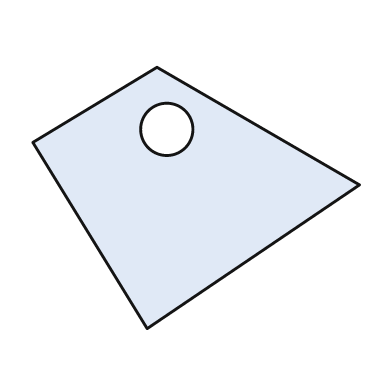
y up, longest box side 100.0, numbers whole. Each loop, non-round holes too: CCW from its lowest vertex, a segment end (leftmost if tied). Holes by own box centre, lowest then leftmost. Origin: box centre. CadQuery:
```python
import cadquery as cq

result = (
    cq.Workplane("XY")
    .moveTo(-15.0, -40.0)
    .lineTo(50.0, 4.0)
    .lineTo(-12.0, 40.0)
    .lineTo(-50.0, 17.0)
    .close()
    .moveTo(-9.0, 21.0)
    .circle(8.0)
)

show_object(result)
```